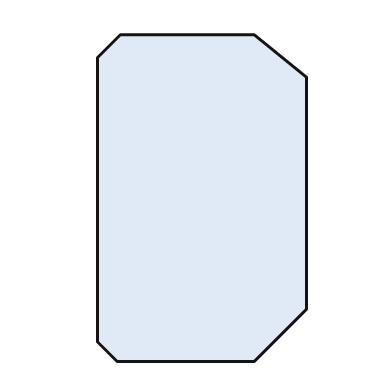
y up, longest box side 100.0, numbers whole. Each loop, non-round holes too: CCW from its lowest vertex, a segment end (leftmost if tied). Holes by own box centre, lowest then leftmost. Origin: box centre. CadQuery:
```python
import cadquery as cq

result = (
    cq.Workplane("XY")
    .moveTo(-26.0, -50.0)
    .lineTo(16.0, -50.0)
    .lineTo(32.0, -34.0)
    .lineTo(32.0, 37.0)
    .lineTo(16.0, 50.0)
    .lineTo(-25.0, 50.0)
    .lineTo(-32.0, 43.0)
    .lineTo(-32.0, -44.0)
    .close()
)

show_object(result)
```